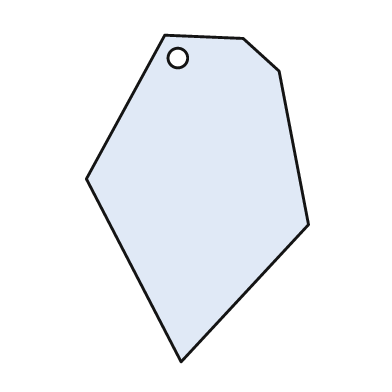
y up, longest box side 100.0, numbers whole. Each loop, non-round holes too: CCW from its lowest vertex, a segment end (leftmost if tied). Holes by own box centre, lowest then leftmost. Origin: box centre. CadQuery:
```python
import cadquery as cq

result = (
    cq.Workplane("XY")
    .moveTo(-5.0, -50.0)
    .lineTo(34.0, -8.0)
    .lineTo(25.0, 39.0)
    .lineTo(14.0, 49.0)
    .lineTo(-10.0, 50.0)
    .lineTo(-34.0, 6.0)
    .close()
    .moveTo(-6.0, 43.0)
    .circle(3.0)
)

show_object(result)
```